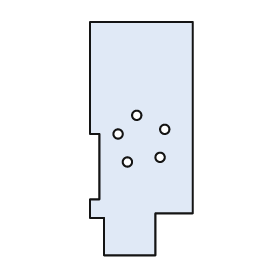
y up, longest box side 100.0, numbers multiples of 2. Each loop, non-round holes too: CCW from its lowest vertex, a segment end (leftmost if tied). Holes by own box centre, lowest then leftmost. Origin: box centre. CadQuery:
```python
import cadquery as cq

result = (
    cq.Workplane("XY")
    .moveTo(-16.0, -50.0)
    .lineTo(6.0, -50.0)
    .lineTo(6.0, -32.0)
    .lineTo(22.0, -32.0)
    .lineTo(22.0, 50.0)
    .lineTo(-22.0, 50.0)
    .lineTo(-22.0, 2.0)
    .lineTo(-18.0, 2.0)
    .lineTo(-18.0, -26.0)
    .lineTo(-22.0, -26.0)
    .lineTo(-22.0, -34.0)
    .lineTo(-16.0, -34.0)
    .close()
    .moveTo(-6.0, -10.0)
    .circle(2.0)
    .moveTo(8.0, -8.0)
    .circle(2.0)
    .moveTo(-10.0, 2.0)
    .circle(2.0)
    .moveTo(10.0, 4.0)
    .circle(2.0)
    .moveTo(-2.0, 10.0)
    .circle(2.0)
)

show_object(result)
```